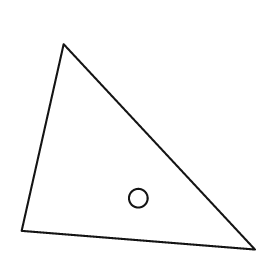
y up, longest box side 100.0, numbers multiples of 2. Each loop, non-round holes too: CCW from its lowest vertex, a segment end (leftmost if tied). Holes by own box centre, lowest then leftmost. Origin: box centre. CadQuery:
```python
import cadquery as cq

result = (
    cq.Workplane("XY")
    .moveTo(50.0, -44.0)
    .lineTo(-32.0, 44.0)
    .lineTo(-50.0, -36.0)
    .close()
    .moveTo(0.0, -22.0)
    .circle(4.0)
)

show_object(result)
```